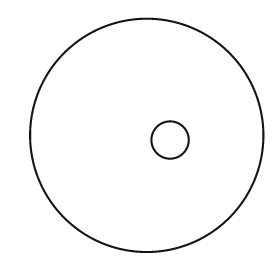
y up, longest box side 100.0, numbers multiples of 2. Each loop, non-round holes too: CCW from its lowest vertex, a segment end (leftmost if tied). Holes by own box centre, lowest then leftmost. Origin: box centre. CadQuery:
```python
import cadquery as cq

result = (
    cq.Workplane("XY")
    .moveTo(0.0, 0.0)
    .circle(50.0)
    .moveTo(10.0, -2.0)
    .circle(8.0)
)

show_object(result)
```